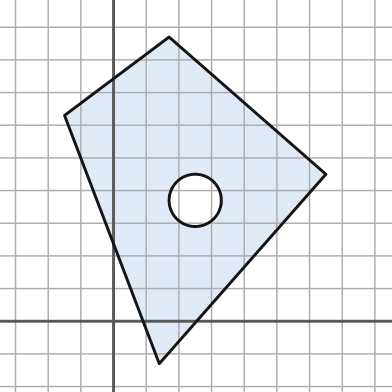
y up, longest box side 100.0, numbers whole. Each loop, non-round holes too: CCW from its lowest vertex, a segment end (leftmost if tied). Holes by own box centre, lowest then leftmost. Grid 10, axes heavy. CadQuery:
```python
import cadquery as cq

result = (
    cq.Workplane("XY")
    .moveTo(14.0, -13.0)
    .lineTo(65.0, 45.0)
    .lineTo(17.0, 87.0)
    .lineTo(-15.0, 63.0)
    .close()
    .moveTo(25.0, 37.0)
    .circle(8.0)
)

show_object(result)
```